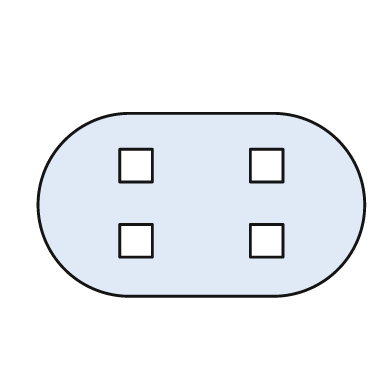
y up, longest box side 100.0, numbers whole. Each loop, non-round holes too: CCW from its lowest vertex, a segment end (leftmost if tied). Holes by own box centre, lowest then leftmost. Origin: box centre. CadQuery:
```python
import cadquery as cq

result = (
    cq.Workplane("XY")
    .moveTo(-22.0, -28.0)
    .lineTo(22.0, -28.0)
    .threePointArc((50.0, 0.0), (22.0, 28.0))
    .lineTo(-22.0, 28.0)
    .threePointArc((-50.0, 0.0), (-22.0, -28.0))
    .close()
    .moveTo(-25.0, -16.0)
    .lineTo(-15.0, -16.0)
    .lineTo(-15.0, -6.0)
    .lineTo(-25.0, -6.0)
    .close()
    .moveTo(15.0, -16.0)
    .lineTo(25.0, -16.0)
    .lineTo(25.0, -6.0)
    .lineTo(15.0, -6.0)
    .close()
    .moveTo(-25.0, 7.0)
    .lineTo(-15.0, 7.0)
    .lineTo(-15.0, 17.0)
    .lineTo(-25.0, 17.0)
    .close()
    .moveTo(15.0, 7.0)
    .lineTo(25.0, 7.0)
    .lineTo(25.0, 17.0)
    .lineTo(15.0, 17.0)
    .close()
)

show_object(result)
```